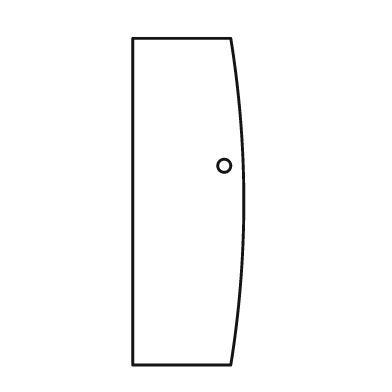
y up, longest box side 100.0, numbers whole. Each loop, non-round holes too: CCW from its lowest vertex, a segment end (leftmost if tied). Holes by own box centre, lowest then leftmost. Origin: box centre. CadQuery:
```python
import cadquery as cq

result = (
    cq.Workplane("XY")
    .moveTo(-17.0, -50.0)
    .lineTo(13.0, -50.0)
    .threePointArc((17.0, 0.0), (13.0, 50.0))
    .lineTo(-17.0, 50.0)
    .close()
    .moveTo(11.0, 11.0)
    .circle(2.0)
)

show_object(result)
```